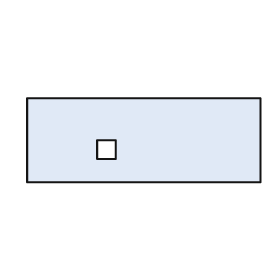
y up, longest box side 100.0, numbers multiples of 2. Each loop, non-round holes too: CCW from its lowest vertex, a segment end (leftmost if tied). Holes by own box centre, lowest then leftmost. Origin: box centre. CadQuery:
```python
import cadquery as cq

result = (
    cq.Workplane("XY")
    .moveTo(-50.0, -18.0)
    .lineTo(50.0, -18.0)
    .lineTo(50.0, 18.0)
    .lineTo(-50.0, 18.0)
    .close()
    .moveTo(-20.0, -8.0)
    .lineTo(-12.0, -8.0)
    .lineTo(-12.0, 0.0)
    .lineTo(-20.0, 0.0)
    .close()
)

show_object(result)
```